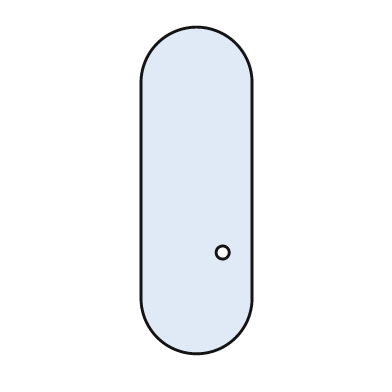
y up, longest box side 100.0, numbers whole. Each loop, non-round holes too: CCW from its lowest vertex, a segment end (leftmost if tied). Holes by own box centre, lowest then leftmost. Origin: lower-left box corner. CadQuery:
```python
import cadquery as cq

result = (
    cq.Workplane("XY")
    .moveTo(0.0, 17.0)
    .threePointArc((17.0, 0.0), (34.0, 17.0))
    .lineTo(34.0, 83.0)
    .threePointArc((17.0, 100.0), (0.0, 83.0))
    .close()
    .moveTo(25.0, 31.0)
    .circle(2.0)
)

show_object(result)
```